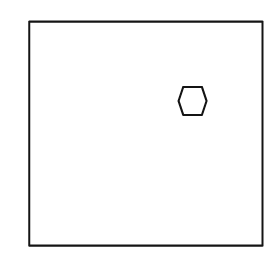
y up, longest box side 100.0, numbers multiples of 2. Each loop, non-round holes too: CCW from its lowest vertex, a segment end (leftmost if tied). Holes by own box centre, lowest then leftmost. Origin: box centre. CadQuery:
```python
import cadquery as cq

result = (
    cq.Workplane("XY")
    .moveTo(-50.0, -48.0)
    .lineTo(50.0, -48.0)
    .lineTo(50.0, 48.0)
    .lineTo(-50.0, 48.0)
    .close()
    .moveTo(16.0, 8.0)
    .lineTo(24.0, 8.0)
    .lineTo(26.0, 14.0)
    .lineTo(24.0, 20.0)
    .lineTo(16.0, 20.0)
    .lineTo(14.0, 14.0)
    .close()
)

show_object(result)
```